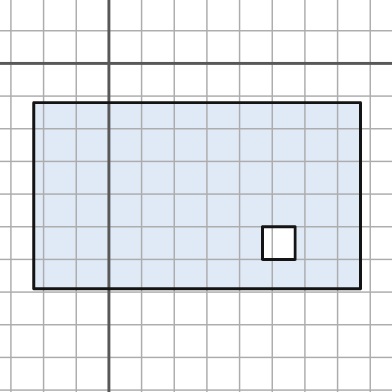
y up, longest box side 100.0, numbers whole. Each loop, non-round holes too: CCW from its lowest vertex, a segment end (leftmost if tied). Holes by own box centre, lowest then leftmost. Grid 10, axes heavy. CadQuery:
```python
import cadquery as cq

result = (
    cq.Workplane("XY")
    .moveTo(-23.0, -69.0)
    .lineTo(77.0, -69.0)
    .lineTo(77.0, -12.0)
    .lineTo(-23.0, -12.0)
    .close()
    .moveTo(47.0, -60.0)
    .lineTo(57.0, -60.0)
    .lineTo(57.0, -50.0)
    .lineTo(47.0, -50.0)
    .close()
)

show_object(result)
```